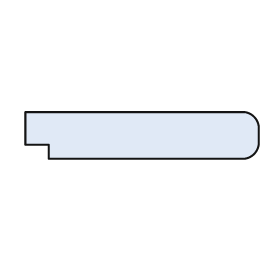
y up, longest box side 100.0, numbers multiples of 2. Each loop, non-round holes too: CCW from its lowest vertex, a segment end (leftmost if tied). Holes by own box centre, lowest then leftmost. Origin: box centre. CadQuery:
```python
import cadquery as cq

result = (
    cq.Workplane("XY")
    .moveTo(-40.0, -10.0)
    .lineTo(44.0, -10.0)
    .threePointArc((48.0, -8.0), (50.0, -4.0))
    .lineTo(50.0, 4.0)
    .threePointArc((48.0, 8.0), (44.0, 10.0))
    .lineTo(-50.0, 10.0)
    .lineTo(-50.0, -4.0)
    .lineTo(-40.0, -4.0)
    .close()
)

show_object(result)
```